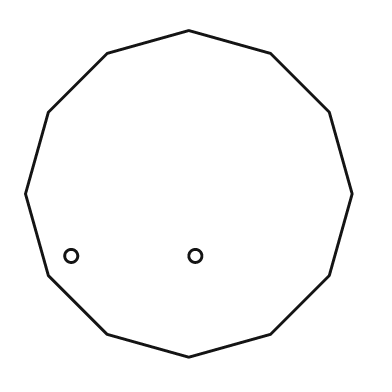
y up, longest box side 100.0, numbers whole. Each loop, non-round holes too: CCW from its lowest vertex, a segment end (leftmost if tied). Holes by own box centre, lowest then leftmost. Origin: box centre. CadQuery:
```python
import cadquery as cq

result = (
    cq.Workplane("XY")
    .moveTo(0.0, -50.0)
    .lineTo(25.0, -43.0)
    .lineTo(43.0, -25.0)
    .lineTo(50.0, 0.0)
    .lineTo(43.0, 25.0)
    .lineTo(25.0, 43.0)
    .lineTo(0.0, 50.0)
    .lineTo(-25.0, 43.0)
    .lineTo(-43.0, 25.0)
    .lineTo(-50.0, 0.0)
    .lineTo(-43.0, -25.0)
    .lineTo(-25.0, -43.0)
    .close()
    .moveTo(-36.0, -19.0)
    .circle(2.0)
    .moveTo(2.0, -19.0)
    .circle(2.0)
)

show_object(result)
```